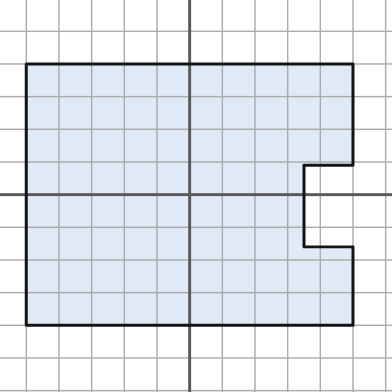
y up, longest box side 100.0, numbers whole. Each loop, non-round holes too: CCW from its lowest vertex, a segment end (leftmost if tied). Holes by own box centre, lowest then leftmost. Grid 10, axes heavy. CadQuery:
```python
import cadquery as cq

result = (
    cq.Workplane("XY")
    .moveTo(-50.0, -40.0)
    .lineTo(50.0, -40.0)
    .lineTo(50.0, -16.0)
    .lineTo(35.0, -16.0)
    .lineTo(35.0, 9.0)
    .lineTo(50.0, 9.0)
    .lineTo(50.0, 40.0)
    .lineTo(-50.0, 40.0)
    .close()
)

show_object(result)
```